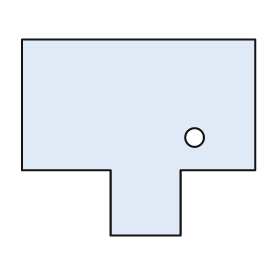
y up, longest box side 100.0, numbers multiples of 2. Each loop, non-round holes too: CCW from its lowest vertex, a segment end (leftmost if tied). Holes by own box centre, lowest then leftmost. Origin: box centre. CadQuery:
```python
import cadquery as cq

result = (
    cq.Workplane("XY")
    .moveTo(-12.0, -42.0)
    .lineTo(18.0, -42.0)
    .lineTo(18.0, -14.0)
    .lineTo(50.0, -14.0)
    .lineTo(50.0, 42.0)
    .lineTo(-50.0, 42.0)
    .lineTo(-50.0, -14.0)
    .lineTo(-12.0, -14.0)
    .close()
    .moveTo(24.0, 0.0)
    .circle(4.0)
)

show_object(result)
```